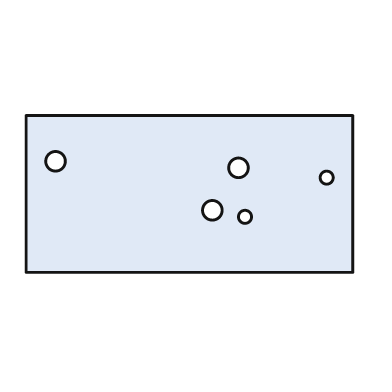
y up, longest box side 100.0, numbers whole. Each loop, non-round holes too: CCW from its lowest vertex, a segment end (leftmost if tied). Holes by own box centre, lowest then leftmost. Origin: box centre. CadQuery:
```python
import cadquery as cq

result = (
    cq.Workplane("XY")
    .moveTo(-50.0, -24.0)
    .lineTo(50.0, -24.0)
    .lineTo(50.0, 24.0)
    .lineTo(-50.0, 24.0)
    .close()
    .moveTo(17.0, -7.0)
    .circle(2.0)
    .moveTo(7.0, -5.0)
    .circle(3.0)
    .moveTo(42.0, 5.0)
    .circle(2.0)
    .moveTo(15.0, 8.0)
    .circle(3.0)
    .moveTo(-41.0, 10.0)
    .circle(3.0)
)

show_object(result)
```